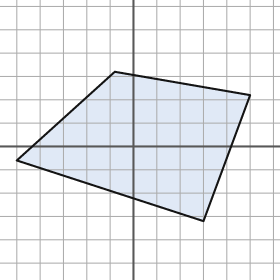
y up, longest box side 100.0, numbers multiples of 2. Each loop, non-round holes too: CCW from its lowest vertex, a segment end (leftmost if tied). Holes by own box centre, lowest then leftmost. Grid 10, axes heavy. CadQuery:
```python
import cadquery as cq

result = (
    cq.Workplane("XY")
    .moveTo(30.0, -32.0)
    .lineTo(50.0, 22.0)
    .lineTo(-8.0, 32.0)
    .lineTo(-50.0, -6.0)
    .close()
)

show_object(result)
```